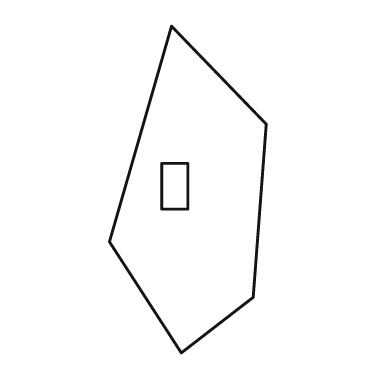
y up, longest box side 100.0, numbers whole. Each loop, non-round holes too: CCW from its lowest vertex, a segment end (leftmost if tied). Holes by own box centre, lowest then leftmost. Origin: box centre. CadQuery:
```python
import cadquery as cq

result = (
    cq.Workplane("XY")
    .moveTo(-2.0, -50.0)
    .lineTo(20.0, -33.0)
    .lineTo(24.0, 20.0)
    .lineTo(-5.0, 50.0)
    .lineTo(-24.0, -16.0)
    .close()
    .moveTo(-8.0, -6.0)
    .lineTo(0.0, -6.0)
    .lineTo(0.0, 8.0)
    .lineTo(-8.0, 8.0)
    .close()
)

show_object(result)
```